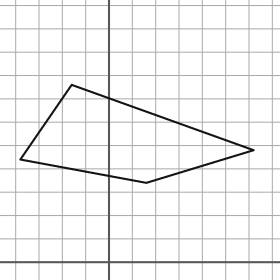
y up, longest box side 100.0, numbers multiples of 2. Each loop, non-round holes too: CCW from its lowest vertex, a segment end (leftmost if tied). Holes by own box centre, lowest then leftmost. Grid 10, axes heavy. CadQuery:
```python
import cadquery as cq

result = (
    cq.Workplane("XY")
    .moveTo(16.0, 34.0)
    .lineTo(62.0, 48.0)
    .lineTo(-16.0, 76.0)
    .lineTo(-38.0, 44.0)
    .close()
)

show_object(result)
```